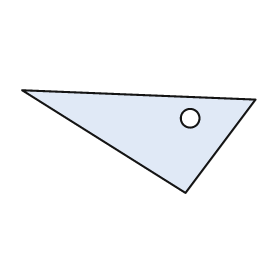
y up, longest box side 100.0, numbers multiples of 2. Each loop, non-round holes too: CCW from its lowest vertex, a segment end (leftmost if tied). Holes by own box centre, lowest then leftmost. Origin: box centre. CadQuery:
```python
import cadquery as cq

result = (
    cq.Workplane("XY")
    .moveTo(20.0, -22.0)
    .lineTo(50.0, 18.0)
    .lineTo(-50.0, 22.0)
    .close()
    .moveTo(22.0, 10.0)
    .circle(4.0)
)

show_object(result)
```